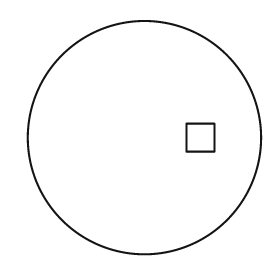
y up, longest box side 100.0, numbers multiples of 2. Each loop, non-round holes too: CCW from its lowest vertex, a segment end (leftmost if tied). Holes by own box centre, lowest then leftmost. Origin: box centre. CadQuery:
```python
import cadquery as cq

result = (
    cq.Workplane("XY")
    .moveTo(0.0, 0.0)
    .circle(50.0)
    .moveTo(18.0, -6.0)
    .lineTo(30.0, -6.0)
    .lineTo(30.0, 6.0)
    .lineTo(18.0, 6.0)
    .close()
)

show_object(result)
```